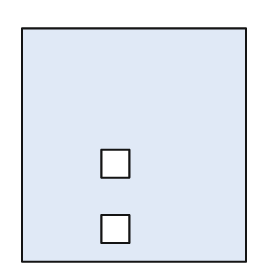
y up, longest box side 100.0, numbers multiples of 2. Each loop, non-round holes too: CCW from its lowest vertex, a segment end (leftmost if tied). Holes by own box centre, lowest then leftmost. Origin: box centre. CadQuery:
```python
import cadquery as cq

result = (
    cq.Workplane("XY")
    .moveTo(-48.0, -50.0)
    .lineTo(48.0, -50.0)
    .lineTo(48.0, 50.0)
    .lineTo(-48.0, 50.0)
    .close()
    .moveTo(-14.0, -42.0)
    .lineTo(-2.0, -42.0)
    .lineTo(-2.0, -30.0)
    .lineTo(-14.0, -30.0)
    .close()
    .moveTo(-14.0, -14.0)
    .lineTo(-2.0, -14.0)
    .lineTo(-2.0, -2.0)
    .lineTo(-14.0, -2.0)
    .close()
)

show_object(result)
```